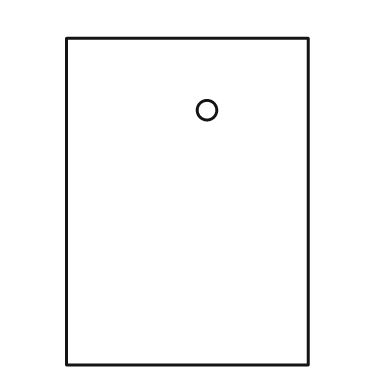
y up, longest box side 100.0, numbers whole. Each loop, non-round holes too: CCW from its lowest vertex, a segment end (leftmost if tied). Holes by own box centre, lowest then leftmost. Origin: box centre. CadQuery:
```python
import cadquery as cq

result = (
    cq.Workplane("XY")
    .moveTo(-37.0, -50.0)
    .lineTo(37.0, -50.0)
    .lineTo(37.0, 50.0)
    .lineTo(-37.0, 50.0)
    .close()
    .moveTo(6.0, 28.0)
    .circle(3.0)
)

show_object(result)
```